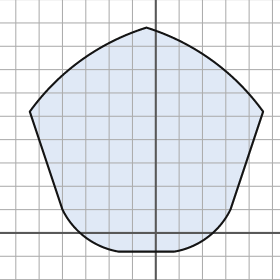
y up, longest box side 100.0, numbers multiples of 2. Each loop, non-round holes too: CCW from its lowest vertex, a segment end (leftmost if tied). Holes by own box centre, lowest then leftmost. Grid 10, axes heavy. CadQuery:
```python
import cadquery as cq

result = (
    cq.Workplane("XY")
    .moveTo(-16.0, -8.0)
    .lineTo(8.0, -8.0)
    .threePointArc((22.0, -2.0), (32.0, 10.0))
    .lineTo(46.0, 52.0)
    .threePointArc((24.0, 74.0), (-4.0, 88.0))
    .threePointArc((-32.0, 74.0), (-54.0, 52.0))
    .lineTo(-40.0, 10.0)
    .threePointArc((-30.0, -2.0), (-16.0, -8.0))
    .close()
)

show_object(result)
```